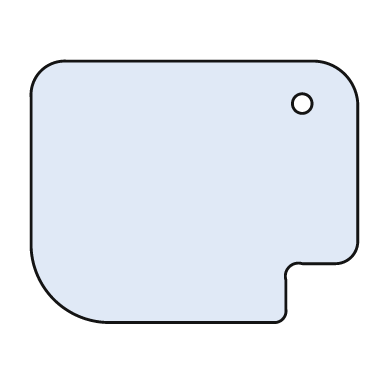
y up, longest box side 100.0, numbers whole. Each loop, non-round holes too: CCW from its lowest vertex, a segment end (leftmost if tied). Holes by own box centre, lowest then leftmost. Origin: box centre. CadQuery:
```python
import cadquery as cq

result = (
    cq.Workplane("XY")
    .moveTo(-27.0, -40.0)
    .lineTo(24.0, -40.0)
    .threePointArc((27.0, -39.0), (28.0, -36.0))
    .lineTo(28.0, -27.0)
    .threePointArc((29.0, -23.0), (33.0, -22.0))
    .lineTo(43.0, -22.0)
    .threePointArc((48.0, -20.0), (50.0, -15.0))
    .lineTo(50.0, 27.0)
    .threePointArc((46.0, 36.0), (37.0, 40.0))
    .lineTo(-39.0, 40.0)
    .threePointArc((-47.0, 37.0), (-50.0, 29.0))
    .lineTo(-50.0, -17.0)
    .threePointArc((-43.0, -33.0), (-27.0, -40.0))
    .close()
    .moveTo(33.0, 27.0)
    .circle(3.0)
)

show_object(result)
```